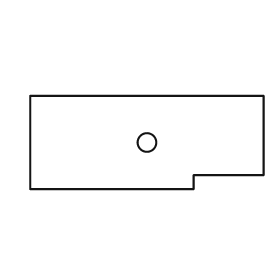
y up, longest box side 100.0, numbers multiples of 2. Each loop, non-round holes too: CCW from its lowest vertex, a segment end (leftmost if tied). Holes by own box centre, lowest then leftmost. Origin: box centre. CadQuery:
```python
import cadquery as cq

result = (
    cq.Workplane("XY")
    .moveTo(-50.0, -20.0)
    .lineTo(20.0, -20.0)
    .lineTo(20.0, -14.0)
    .lineTo(50.0, -14.0)
    .lineTo(50.0, 20.0)
    .lineTo(-50.0, 20.0)
    .close()
    .moveTo(0.0, 0.0)
    .circle(4.0)
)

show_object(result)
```